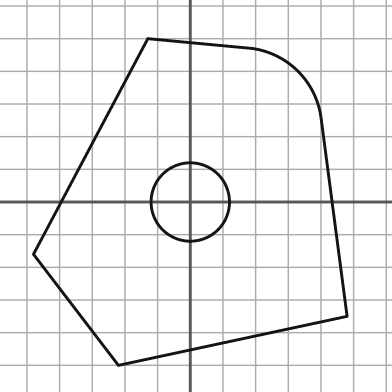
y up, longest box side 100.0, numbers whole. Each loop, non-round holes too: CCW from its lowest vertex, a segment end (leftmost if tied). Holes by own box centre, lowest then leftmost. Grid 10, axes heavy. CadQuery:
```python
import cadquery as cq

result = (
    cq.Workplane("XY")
    .moveTo(-22.0, -50.0)
    .lineTo(48.0, -35.0)
    .lineTo(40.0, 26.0)
    .threePointArc((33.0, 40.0), (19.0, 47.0))
    .lineTo(-13.0, 50.0)
    .lineTo(-48.0, -16.0)
    .close()
    .moveTo(0.0, 0.0)
    .circle(12.0)
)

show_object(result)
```